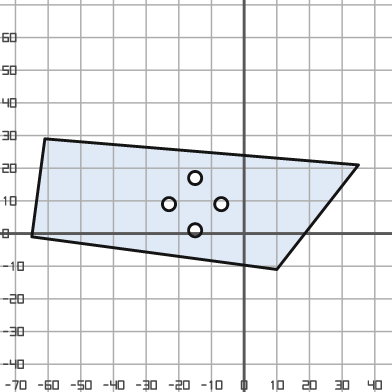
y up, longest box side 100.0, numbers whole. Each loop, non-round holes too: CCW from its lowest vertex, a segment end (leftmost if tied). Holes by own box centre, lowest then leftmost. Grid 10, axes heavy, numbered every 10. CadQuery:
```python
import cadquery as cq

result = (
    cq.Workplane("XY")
    .moveTo(10.0, -11.0)
    .lineTo(35.0, 21.0)
    .lineTo(-61.0, 29.0)
    .lineTo(-65.0, -1.0)
    .close()
    .moveTo(-15.0, 1.0)
    .circle(2.0)
    .moveTo(-23.0, 9.0)
    .circle(2.0)
    .moveTo(-7.0, 9.0)
    .circle(2.0)
    .moveTo(-15.0, 17.0)
    .circle(2.0)
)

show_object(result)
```